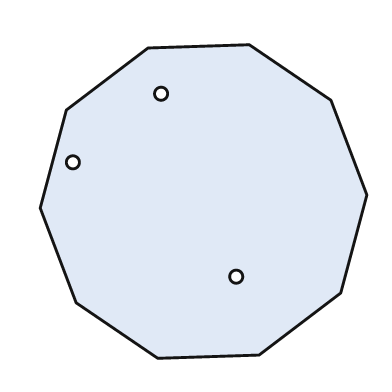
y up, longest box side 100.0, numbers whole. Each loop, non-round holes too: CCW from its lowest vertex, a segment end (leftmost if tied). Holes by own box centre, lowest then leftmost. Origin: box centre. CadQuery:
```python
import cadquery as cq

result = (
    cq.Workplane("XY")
    .moveTo(-14.0, -48.0)
    .lineTo(17.0, -47.0)
    .lineTo(42.0, -28.0)
    .lineTo(50.0, 2.0)
    .lineTo(39.0, 31.0)
    .lineTo(14.0, 48.0)
    .lineTo(-17.0, 47.0)
    .lineTo(-42.0, 28.0)
    .lineTo(-50.0, -2.0)
    .lineTo(-39.0, -31.0)
    .close()
    .moveTo(10.0, -23.0)
    .circle(2.0)
    .moveTo(-40.0, 12.0)
    .circle(2.0)
    .moveTo(-13.0, 33.0)
    .circle(2.0)
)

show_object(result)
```